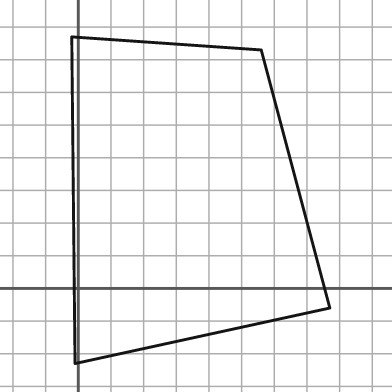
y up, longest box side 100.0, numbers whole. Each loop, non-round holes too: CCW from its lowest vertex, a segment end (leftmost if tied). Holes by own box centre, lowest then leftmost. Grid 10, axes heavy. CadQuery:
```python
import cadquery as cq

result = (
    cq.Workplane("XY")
    .moveTo(-1.0, -23.0)
    .lineTo(77.0, -6.0)
    .lineTo(56.0, 73.0)
    .lineTo(-2.0, 77.0)
    .close()
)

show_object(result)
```